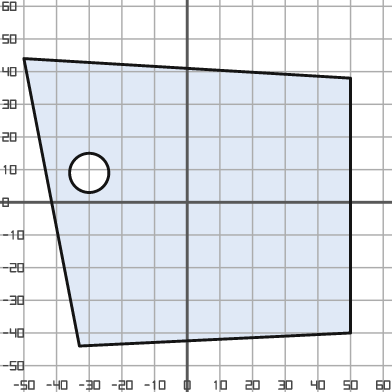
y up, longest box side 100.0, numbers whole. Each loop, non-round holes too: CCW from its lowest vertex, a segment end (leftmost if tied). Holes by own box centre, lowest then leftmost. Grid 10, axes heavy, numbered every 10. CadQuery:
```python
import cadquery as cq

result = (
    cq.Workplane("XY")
    .moveTo(-33.0, -44.0)
    .lineTo(50.0, -40.0)
    .lineTo(50.0, 38.0)
    .lineTo(-50.0, 44.0)
    .close()
    .moveTo(-30.0, 9.0)
    .circle(6.0)
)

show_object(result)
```